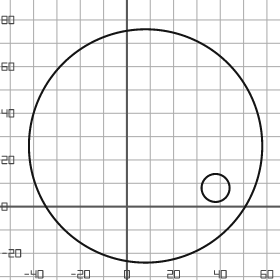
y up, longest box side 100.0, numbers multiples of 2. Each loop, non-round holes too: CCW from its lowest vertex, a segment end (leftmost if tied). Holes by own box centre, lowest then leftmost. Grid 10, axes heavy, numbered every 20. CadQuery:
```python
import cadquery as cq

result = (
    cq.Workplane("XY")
    .moveTo(8.0, 26.0)
    .circle(50.0)
    .moveTo(38.0, 8.0)
    .circle(6.0)
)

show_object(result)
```